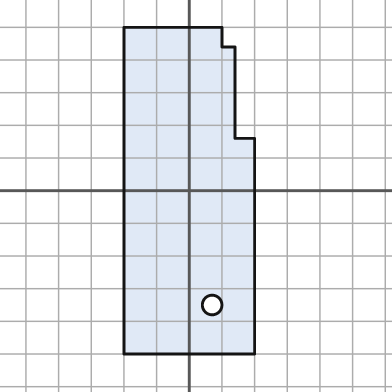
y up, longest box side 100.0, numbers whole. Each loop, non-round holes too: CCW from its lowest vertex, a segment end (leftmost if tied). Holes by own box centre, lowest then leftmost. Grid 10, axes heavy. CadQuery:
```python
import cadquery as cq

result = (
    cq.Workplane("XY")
    .moveTo(-20.0, -50.0)
    .lineTo(20.0, -50.0)
    .lineTo(20.0, 16.0)
    .lineTo(14.0, 16.0)
    .lineTo(14.0, 44.0)
    .lineTo(10.0, 44.0)
    .lineTo(10.0, 50.0)
    .lineTo(-20.0, 50.0)
    .close()
    .moveTo(7.0, -35.0)
    .circle(3.0)
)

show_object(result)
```